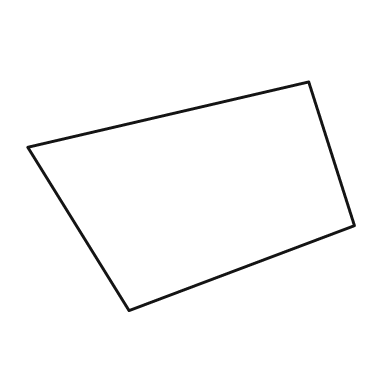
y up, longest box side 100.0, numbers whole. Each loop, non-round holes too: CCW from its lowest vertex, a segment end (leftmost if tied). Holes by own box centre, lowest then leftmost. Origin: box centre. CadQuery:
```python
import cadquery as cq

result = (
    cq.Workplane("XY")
    .moveTo(-19.0, -35.0)
    .lineTo(50.0, -9.0)
    .lineTo(36.0, 35.0)
    .lineTo(-50.0, 15.0)
    .close()
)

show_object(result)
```